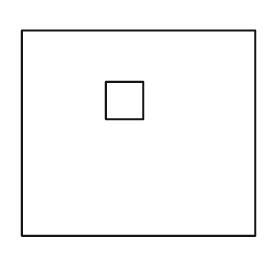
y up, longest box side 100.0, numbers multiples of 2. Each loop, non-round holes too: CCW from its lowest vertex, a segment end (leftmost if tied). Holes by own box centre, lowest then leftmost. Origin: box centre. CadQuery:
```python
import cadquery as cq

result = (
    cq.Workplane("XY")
    .moveTo(-50.0, -44.0)
    .lineTo(50.0, -44.0)
    .lineTo(50.0, 44.0)
    .lineTo(-50.0, 44.0)
    .close()
    .moveTo(-14.0, 6.0)
    .lineTo(2.0, 6.0)
    .lineTo(2.0, 22.0)
    .lineTo(-14.0, 22.0)
    .close()
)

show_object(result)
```